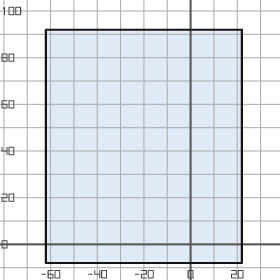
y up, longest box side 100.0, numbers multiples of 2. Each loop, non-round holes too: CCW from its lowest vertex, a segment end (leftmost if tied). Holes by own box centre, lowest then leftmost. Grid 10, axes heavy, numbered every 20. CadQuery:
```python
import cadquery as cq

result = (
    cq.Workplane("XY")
    .moveTo(-62.0, -8.0)
    .lineTo(22.0, -8.0)
    .lineTo(22.0, 92.0)
    .lineTo(-62.0, 92.0)
    .close()
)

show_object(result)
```